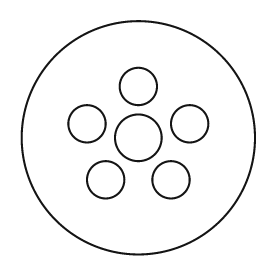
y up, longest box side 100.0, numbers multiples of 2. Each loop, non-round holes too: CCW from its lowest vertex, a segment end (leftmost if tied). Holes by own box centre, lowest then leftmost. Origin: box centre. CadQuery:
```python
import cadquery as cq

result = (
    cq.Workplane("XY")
    .moveTo(0.0, 0.0)
    .circle(50.0)
    .moveTo(-14.0, -18.0)
    .circle(8.0)
    .moveTo(14.0, -18.0)
    .circle(8.0)
    .moveTo(0.0, 0.0)
    .circle(10.0)
    .moveTo(-22.0, 6.0)
    .circle(8.0)
    .moveTo(22.0, 6.0)
    .circle(8.0)
    .moveTo(0.0, 22.0)
    .circle(8.0)
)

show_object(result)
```